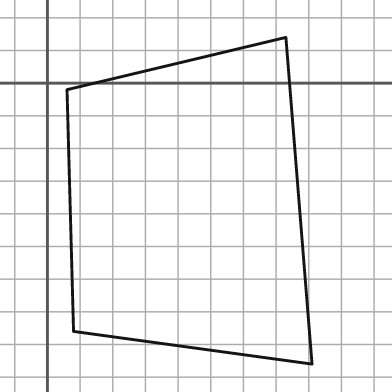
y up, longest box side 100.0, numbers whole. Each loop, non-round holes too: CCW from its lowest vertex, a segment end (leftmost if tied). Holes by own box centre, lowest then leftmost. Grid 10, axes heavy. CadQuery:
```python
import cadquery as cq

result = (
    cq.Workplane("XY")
    .moveTo(81.0, -86.0)
    .lineTo(73.0, 14.0)
    .lineTo(6.0, -2.0)
    .lineTo(8.0, -76.0)
    .close()
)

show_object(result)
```